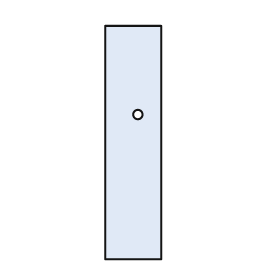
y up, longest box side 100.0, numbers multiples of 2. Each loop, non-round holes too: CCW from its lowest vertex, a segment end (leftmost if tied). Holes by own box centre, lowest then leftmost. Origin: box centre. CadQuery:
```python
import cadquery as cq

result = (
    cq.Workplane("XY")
    .moveTo(-12.0, -50.0)
    .lineTo(12.0, -50.0)
    .lineTo(12.0, 50.0)
    .lineTo(-12.0, 50.0)
    .close()
    .moveTo(2.0, 12.0)
    .circle(2.0)
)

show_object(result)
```